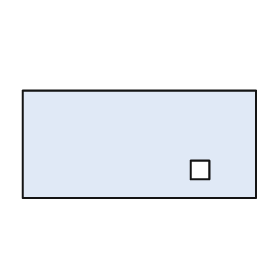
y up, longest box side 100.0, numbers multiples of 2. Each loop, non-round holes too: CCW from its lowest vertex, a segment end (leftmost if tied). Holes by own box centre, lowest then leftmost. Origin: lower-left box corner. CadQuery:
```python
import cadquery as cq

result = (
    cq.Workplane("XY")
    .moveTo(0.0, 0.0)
    .lineTo(100.0, 0.0)
    .lineTo(100.0, 46.0)
    .lineTo(0.0, 46.0)
    .close()
    .moveTo(72.0, 8.0)
    .lineTo(80.0, 8.0)
    .lineTo(80.0, 16.0)
    .lineTo(72.0, 16.0)
    .close()
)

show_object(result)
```